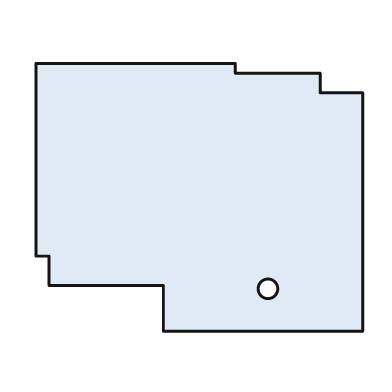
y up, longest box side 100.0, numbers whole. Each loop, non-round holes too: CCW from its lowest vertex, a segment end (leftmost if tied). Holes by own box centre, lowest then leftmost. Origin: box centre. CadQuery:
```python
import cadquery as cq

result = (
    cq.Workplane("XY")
    .moveTo(-11.0, -41.0)
    .lineTo(50.0, -41.0)
    .lineTo(50.0, 32.0)
    .lineTo(37.0, 32.0)
    .lineTo(37.0, 38.0)
    .lineTo(11.0, 38.0)
    .lineTo(11.0, 41.0)
    .lineTo(-50.0, 41.0)
    .lineTo(-50.0, -18.0)
    .lineTo(-46.0, -18.0)
    .lineTo(-46.0, -27.0)
    .lineTo(-11.0, -27.0)
    .close()
    .moveTo(21.0, -28.0)
    .circle(3.0)
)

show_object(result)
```